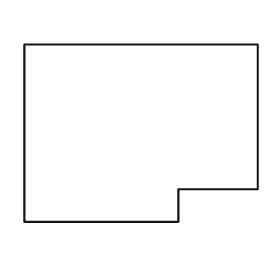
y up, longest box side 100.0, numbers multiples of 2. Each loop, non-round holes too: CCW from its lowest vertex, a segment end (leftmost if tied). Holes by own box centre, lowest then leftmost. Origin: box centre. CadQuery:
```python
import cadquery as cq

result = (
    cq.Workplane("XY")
    .moveTo(-50.0, -38.0)
    .lineTo(16.0, -38.0)
    .lineTo(16.0, -24.0)
    .lineTo(50.0, -24.0)
    .lineTo(50.0, 38.0)
    .lineTo(-50.0, 38.0)
    .close()
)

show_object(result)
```